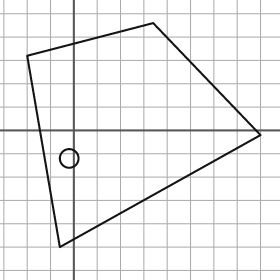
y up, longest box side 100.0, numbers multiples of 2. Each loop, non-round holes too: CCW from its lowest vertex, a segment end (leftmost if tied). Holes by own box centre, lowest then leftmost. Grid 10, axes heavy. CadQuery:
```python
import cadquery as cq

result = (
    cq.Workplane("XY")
    .moveTo(-6.0, -50.0)
    .lineTo(80.0, -2.0)
    .lineTo(34.0, 46.0)
    .lineTo(-20.0, 32.0)
    .close()
    .moveTo(-2.0, -12.0)
    .circle(4.0)
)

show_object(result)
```